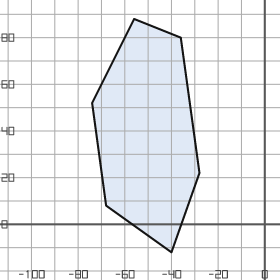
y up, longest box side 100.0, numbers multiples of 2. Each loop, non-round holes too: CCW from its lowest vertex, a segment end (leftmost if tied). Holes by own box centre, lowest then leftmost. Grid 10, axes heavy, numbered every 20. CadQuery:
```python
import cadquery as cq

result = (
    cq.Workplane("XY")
    .moveTo(-40.0, -12.0)
    .lineTo(-28.0, 22.0)
    .lineTo(-36.0, 80.0)
    .lineTo(-56.0, 88.0)
    .lineTo(-74.0, 52.0)
    .lineTo(-68.0, 8.0)
    .close()
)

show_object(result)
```